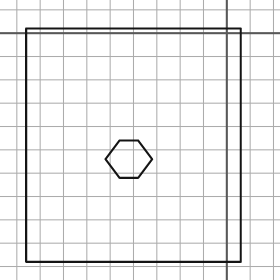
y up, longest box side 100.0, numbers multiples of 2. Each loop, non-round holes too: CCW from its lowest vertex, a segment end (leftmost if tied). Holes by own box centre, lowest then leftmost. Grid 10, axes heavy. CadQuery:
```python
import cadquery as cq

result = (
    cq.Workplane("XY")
    .moveTo(-86.0, -98.0)
    .lineTo(6.0, -98.0)
    .lineTo(6.0, 2.0)
    .lineTo(-86.0, 2.0)
    .close()
    .moveTo(-46.0, -62.0)
    .lineTo(-38.0, -62.0)
    .lineTo(-32.0, -54.0)
    .lineTo(-38.0, -46.0)
    .lineTo(-46.0, -46.0)
    .lineTo(-52.0, -54.0)
    .close()
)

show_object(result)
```